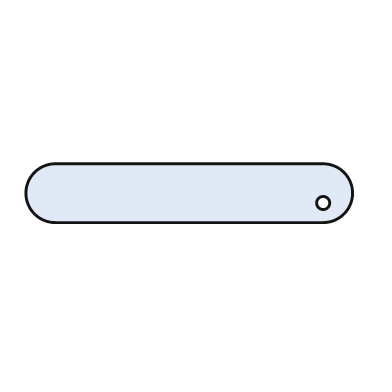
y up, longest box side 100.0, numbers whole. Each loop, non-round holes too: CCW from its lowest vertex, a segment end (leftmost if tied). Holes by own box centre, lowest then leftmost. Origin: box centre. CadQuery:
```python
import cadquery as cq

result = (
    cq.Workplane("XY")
    .moveTo(-41.0, -9.0)
    .lineTo(41.0, -9.0)
    .threePointArc((50.0, 0.0), (41.0, 9.0))
    .lineTo(-41.0, 9.0)
    .threePointArc((-50.0, 0.0), (-41.0, -9.0))
    .close()
    .moveTo(41.0, -3.0)
    .circle(2.0)
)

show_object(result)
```